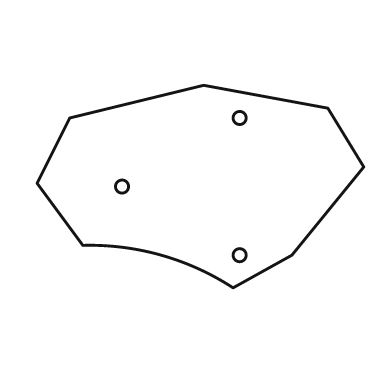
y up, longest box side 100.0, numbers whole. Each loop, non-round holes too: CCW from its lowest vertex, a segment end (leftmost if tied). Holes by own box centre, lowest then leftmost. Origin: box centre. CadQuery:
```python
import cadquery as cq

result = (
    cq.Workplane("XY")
    .moveTo(10.0, -31.0)
    .lineTo(28.0, -21.0)
    .lineTo(50.0, 6.0)
    .lineTo(39.0, 24.0)
    .lineTo(1.0, 31.0)
    .lineTo(-40.0, 21.0)
    .lineTo(-50.0, 1.0)
    .lineTo(-36.0, -18.0)
    .threePointArc((-12.0, -21.0), (10.0, -31.0))
    .close()
    .moveTo(12.0, -21.0)
    .circle(2.0)
    .moveTo(-24.0, 0.0)
    .circle(2.0)
    .moveTo(12.0, 21.0)
    .circle(2.0)
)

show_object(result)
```